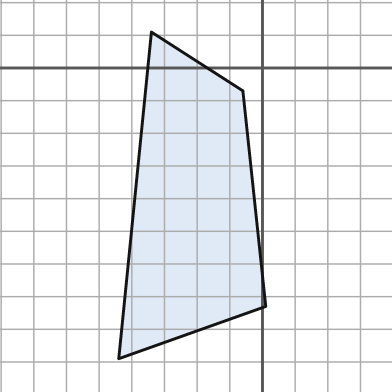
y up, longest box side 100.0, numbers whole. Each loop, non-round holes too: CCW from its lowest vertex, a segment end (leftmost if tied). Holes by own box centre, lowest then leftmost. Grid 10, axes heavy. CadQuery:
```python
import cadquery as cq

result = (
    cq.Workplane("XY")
    .moveTo(-44.0, -89.0)
    .lineTo(1.0, -73.0)
    .lineTo(-6.0, -7.0)
    .lineTo(-34.0, 11.0)
    .close()
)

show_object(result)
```